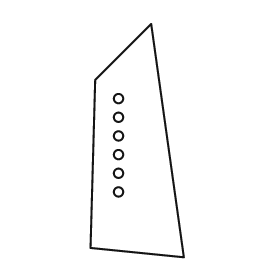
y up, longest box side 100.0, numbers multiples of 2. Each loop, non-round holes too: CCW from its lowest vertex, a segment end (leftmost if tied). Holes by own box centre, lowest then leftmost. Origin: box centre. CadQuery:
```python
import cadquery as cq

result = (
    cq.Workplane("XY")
    .moveTo(20.0, -50.0)
    .lineTo(6.0, 50.0)
    .lineTo(-18.0, 26.0)
    .lineTo(-20.0, -46.0)
    .close()
    .moveTo(-8.0, -22.0)
    .circle(2.0)
    .moveTo(-8.0, -14.0)
    .circle(2.0)
    .moveTo(-8.0, -6.0)
    .circle(2.0)
    .moveTo(-8.0, 2.0)
    .circle(2.0)
    .moveTo(-8.0, 10.0)
    .circle(2.0)
    .moveTo(-8.0, 18.0)
    .circle(2.0)
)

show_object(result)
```